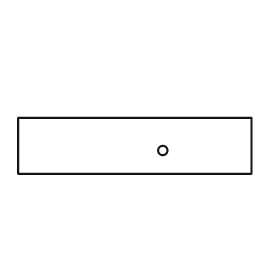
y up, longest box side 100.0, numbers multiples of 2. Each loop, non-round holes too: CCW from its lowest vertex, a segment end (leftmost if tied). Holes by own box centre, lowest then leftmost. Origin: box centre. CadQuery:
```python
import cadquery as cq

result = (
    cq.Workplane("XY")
    .moveTo(-50.0, -12.0)
    .lineTo(50.0, -12.0)
    .lineTo(50.0, 12.0)
    .lineTo(-50.0, 12.0)
    .close()
    .moveTo(12.0, -2.0)
    .circle(2.0)
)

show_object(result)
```